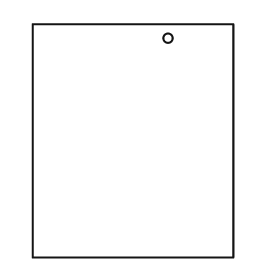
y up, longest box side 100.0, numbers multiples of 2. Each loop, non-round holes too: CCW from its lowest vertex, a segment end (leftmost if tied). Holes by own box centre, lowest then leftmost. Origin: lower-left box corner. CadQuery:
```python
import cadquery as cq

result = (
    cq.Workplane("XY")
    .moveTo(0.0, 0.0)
    .lineTo(86.0, 0.0)
    .lineTo(86.0, 100.0)
    .lineTo(0.0, 100.0)
    .close()
    .moveTo(58.0, 94.0)
    .circle(2.0)
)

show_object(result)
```